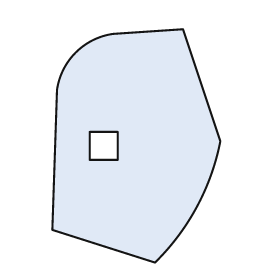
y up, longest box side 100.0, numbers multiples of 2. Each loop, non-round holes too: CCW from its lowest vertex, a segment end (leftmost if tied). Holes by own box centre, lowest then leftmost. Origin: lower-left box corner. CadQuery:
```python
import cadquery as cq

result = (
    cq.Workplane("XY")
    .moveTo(44.0, 0.0)
    .threePointArc((62.0, 24.0), (72.0, 52.0))
    .lineTo(56.0, 100.0)
    .lineTo(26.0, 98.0)
    .threePointArc((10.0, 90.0), (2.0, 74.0))
    .lineTo(0.0, 14.0)
    .close()
    .moveTo(16.0, 44.0)
    .lineTo(28.0, 44.0)
    .lineTo(28.0, 56.0)
    .lineTo(16.0, 56.0)
    .close()
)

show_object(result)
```